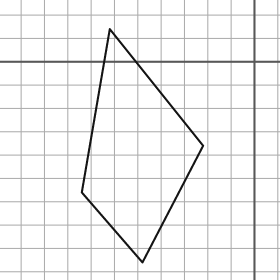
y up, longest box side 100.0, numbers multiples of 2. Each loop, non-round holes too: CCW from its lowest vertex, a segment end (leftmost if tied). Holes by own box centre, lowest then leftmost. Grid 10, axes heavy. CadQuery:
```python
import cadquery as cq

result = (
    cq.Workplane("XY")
    .moveTo(-48.0, -86.0)
    .lineTo(-22.0, -36.0)
    .lineTo(-62.0, 14.0)
    .lineTo(-74.0, -56.0)
    .close()
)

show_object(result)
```